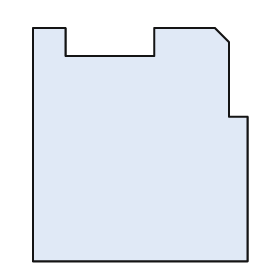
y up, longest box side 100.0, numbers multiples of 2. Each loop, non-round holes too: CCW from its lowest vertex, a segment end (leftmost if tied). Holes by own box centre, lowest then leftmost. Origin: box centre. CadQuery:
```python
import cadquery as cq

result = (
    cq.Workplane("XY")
    .moveTo(-46.0, -50.0)
    .lineTo(46.0, -50.0)
    .lineTo(46.0, 12.0)
    .lineTo(38.0, 12.0)
    .lineTo(38.0, 44.0)
    .lineTo(32.0, 50.0)
    .lineTo(6.0, 50.0)
    .lineTo(6.0, 38.0)
    .lineTo(-32.0, 38.0)
    .lineTo(-32.0, 50.0)
    .lineTo(-46.0, 50.0)
    .close()
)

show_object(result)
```